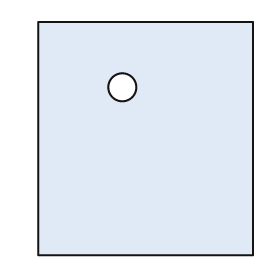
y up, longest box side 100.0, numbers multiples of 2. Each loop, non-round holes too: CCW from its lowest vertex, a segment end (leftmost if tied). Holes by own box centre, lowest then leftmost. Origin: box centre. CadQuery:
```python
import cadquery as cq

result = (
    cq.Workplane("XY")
    .moveTo(-46.0, -50.0)
    .lineTo(46.0, -50.0)
    .lineTo(46.0, 50.0)
    .lineTo(-46.0, 50.0)
    .close()
    .moveTo(-10.0, 22.0)
    .circle(6.0)
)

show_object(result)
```